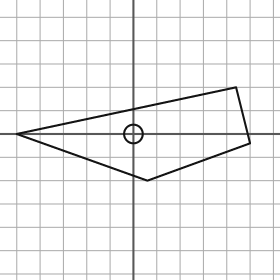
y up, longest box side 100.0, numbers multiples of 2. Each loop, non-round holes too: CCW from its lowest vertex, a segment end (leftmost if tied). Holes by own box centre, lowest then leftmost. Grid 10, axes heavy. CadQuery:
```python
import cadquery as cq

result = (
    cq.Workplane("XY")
    .moveTo(6.0, -20.0)
    .lineTo(50.0, -4.0)
    .lineTo(44.0, 20.0)
    .lineTo(-50.0, 0.0)
    .close()
    .moveTo(0.0, 0.0)
    .circle(4.0)
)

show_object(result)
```